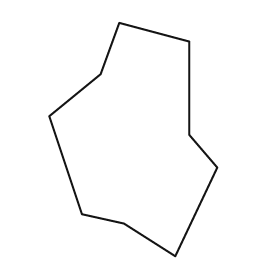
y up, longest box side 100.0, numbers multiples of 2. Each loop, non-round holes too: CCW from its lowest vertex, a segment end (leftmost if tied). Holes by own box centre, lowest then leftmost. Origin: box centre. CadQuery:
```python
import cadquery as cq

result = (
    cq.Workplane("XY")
    .moveTo(18.0, -50.0)
    .lineTo(36.0, -12.0)
    .lineTo(24.0, 2.0)
    .lineTo(24.0, 42.0)
    .lineTo(-6.0, 50.0)
    .lineTo(-14.0, 28.0)
    .lineTo(-36.0, 10.0)
    .lineTo(-22.0, -32.0)
    .lineTo(-4.0, -36.0)
    .close()
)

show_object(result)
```